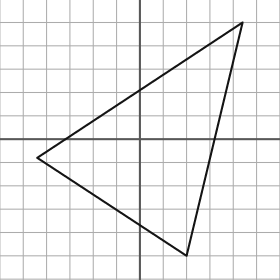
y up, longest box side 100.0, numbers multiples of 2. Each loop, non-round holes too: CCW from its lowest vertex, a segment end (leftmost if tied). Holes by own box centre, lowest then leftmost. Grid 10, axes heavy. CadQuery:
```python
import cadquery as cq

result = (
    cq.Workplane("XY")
    .moveTo(20.0, -50.0)
    .lineTo(44.0, 50.0)
    .lineTo(-44.0, -8.0)
    .close()
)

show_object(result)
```